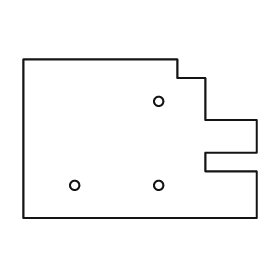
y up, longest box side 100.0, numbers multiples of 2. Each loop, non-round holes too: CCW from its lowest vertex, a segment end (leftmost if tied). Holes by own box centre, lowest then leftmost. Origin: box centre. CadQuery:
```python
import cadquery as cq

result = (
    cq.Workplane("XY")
    .moveTo(-50.0, -34.0)
    .lineTo(50.0, -34.0)
    .lineTo(50.0, -14.0)
    .lineTo(28.0, -14.0)
    .lineTo(28.0, -6.0)
    .lineTo(50.0, -6.0)
    .lineTo(50.0, 8.0)
    .lineTo(28.0, 8.0)
    .lineTo(28.0, 26.0)
    .lineTo(16.0, 26.0)
    .lineTo(16.0, 34.0)
    .lineTo(-50.0, 34.0)
    .close()
    .moveTo(-28.0, -20.0)
    .circle(2.0)
    .moveTo(8.0, -20.0)
    .circle(2.0)
    .moveTo(8.0, 16.0)
    .circle(2.0)
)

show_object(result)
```